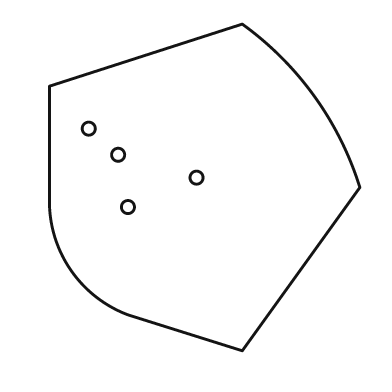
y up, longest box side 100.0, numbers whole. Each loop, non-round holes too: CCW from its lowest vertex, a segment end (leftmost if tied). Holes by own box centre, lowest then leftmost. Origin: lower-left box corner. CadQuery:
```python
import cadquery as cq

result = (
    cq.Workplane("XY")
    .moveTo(59.0, 0.0)
    .lineTo(95.0, 50.0)
    .threePointArc((81.0, 78.0), (59.0, 100.0))
    .lineTo(0.0, 81.0)
    .lineTo(0.0, 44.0)
    .threePointArc((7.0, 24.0), (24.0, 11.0))
    .close()
    .moveTo(24.0, 44.0)
    .circle(2.0)
    .moveTo(45.0, 53.0)
    .circle(2.0)
    .moveTo(21.0, 60.0)
    .circle(2.0)
    .moveTo(12.0, 68.0)
    .circle(2.0)
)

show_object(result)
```